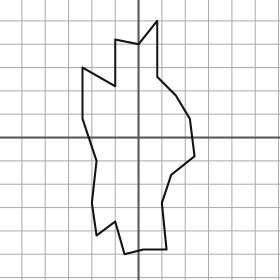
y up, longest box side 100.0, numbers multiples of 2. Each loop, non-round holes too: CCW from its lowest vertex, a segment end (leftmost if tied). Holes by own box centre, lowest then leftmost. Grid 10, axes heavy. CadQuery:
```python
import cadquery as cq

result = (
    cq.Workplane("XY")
    .moveTo(-6.0, -50.0)
    .lineTo(2.0, -48.0)
    .lineTo(12.0, -48.0)
    .lineTo(10.0, -28.0)
    .lineTo(14.0, -16.0)
    .lineTo(24.0, -8.0)
    .lineTo(22.0, 8.0)
    .lineTo(16.0, 18.0)
    .lineTo(8.0, 26.0)
    .lineTo(8.0, 50.0)
    .lineTo(0.0, 40.0)
    .lineTo(-10.0, 42.0)
    .lineTo(-10.0, 22.0)
    .lineTo(-24.0, 30.0)
    .lineTo(-24.0, 8.0)
    .lineTo(-18.0, -10.0)
    .lineTo(-20.0, -28.0)
    .lineTo(-18.0, -42.0)
    .lineTo(-10.0, -36.0)
    .close()
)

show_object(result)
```